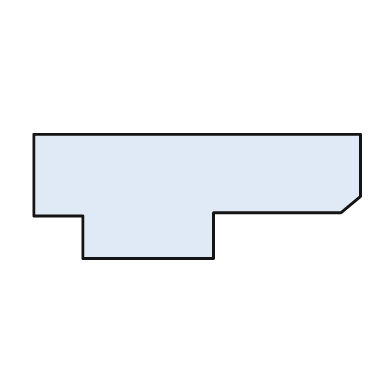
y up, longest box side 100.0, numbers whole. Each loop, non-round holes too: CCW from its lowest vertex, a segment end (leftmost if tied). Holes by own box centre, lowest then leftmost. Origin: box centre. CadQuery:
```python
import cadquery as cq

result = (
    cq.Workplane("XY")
    .moveTo(-35.0, -19.0)
    .lineTo(5.0, -19.0)
    .lineTo(5.0, -5.0)
    .lineTo(44.0, -5.0)
    .lineTo(50.0, 0.0)
    .lineTo(50.0, 19.0)
    .lineTo(-50.0, 19.0)
    .lineTo(-50.0, -6.0)
    .lineTo(-35.0, -6.0)
    .close()
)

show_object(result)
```